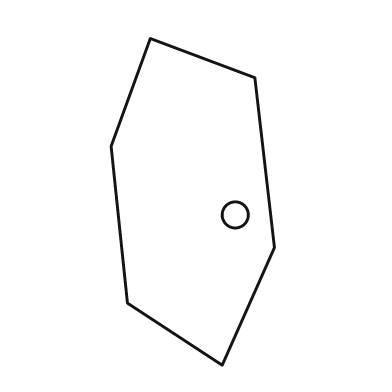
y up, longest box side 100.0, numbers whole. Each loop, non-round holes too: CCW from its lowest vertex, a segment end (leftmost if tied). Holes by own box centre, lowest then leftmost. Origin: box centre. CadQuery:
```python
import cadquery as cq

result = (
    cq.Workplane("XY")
    .moveTo(9.0, -50.0)
    .lineTo(25.0, -14.0)
    .lineTo(19.0, 38.0)
    .lineTo(-13.0, 50.0)
    .lineTo(-25.0, 17.0)
    .lineTo(-20.0, -31.0)
    .close()
    .moveTo(13.0, -4.0)
    .circle(4.0)
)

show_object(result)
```